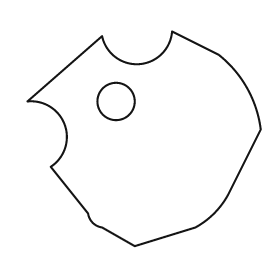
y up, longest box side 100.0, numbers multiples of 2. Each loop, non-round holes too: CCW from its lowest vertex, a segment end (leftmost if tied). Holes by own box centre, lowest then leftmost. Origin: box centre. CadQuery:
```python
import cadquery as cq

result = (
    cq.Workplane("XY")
    .moveTo(-4.0, -46.0)
    .lineTo(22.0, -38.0)
    .threePointArc((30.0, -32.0), (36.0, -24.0))
    .lineTo(50.0, 4.0)
    .threePointArc((44.0, 22.0), (32.0, 36.0))
    .lineTo(12.0, 46.0)
    .threePointArc((-2.0, 32.0), (-18.0, 44.0))
    .lineTo(-50.0, 16.0)
    .threePointArc((-34.0, 6.0), (-40.0, -12.0))
    .lineTo(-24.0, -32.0)
    .threePointArc((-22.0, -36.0), (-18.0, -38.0))
    .close()
    .moveTo(-12.0, 16.0)
    .circle(8.0)
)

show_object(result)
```